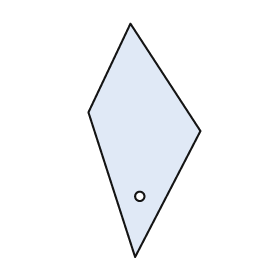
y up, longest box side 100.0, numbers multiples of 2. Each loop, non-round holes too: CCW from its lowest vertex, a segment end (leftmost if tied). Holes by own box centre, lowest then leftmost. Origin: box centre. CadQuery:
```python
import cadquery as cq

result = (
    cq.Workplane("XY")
    .moveTo(-4.0, -50.0)
    .lineTo(24.0, 4.0)
    .lineTo(-6.0, 50.0)
    .lineTo(-24.0, 12.0)
    .close()
    .moveTo(-2.0, -24.0)
    .circle(2.0)
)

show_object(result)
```